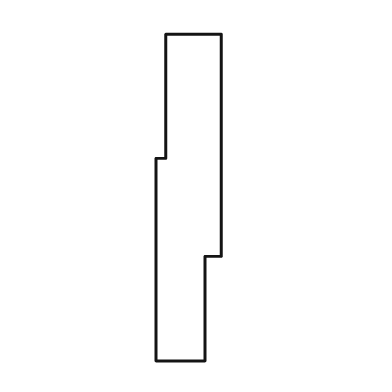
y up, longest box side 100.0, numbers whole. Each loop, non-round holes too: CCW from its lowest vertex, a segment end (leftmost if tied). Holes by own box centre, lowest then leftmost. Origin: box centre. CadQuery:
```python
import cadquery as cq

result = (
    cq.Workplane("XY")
    .moveTo(-10.0, -50.0)
    .lineTo(5.0, -50.0)
    .lineTo(5.0, -18.0)
    .lineTo(10.0, -18.0)
    .lineTo(10.0, 50.0)
    .lineTo(-7.0, 50.0)
    .lineTo(-7.0, 12.0)
    .lineTo(-10.0, 12.0)
    .close()
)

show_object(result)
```